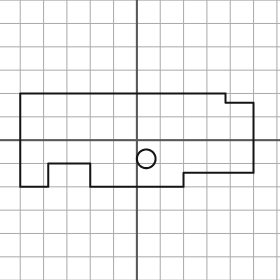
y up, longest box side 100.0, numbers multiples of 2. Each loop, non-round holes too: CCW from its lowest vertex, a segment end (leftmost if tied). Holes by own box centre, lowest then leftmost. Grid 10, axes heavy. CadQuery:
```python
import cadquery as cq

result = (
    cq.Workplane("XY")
    .moveTo(-50.0, -20.0)
    .lineTo(-38.0, -20.0)
    .lineTo(-38.0, -10.0)
    .lineTo(-20.0, -10.0)
    .lineTo(-20.0, -20.0)
    .lineTo(20.0, -20.0)
    .lineTo(20.0, -14.0)
    .lineTo(50.0, -14.0)
    .lineTo(50.0, 16.0)
    .lineTo(38.0, 16.0)
    .lineTo(38.0, 20.0)
    .lineTo(-50.0, 20.0)
    .close()
    .moveTo(4.0, -8.0)
    .circle(4.0)
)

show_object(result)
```